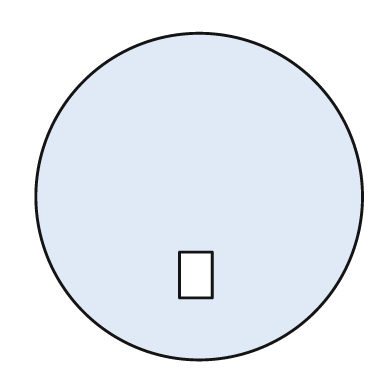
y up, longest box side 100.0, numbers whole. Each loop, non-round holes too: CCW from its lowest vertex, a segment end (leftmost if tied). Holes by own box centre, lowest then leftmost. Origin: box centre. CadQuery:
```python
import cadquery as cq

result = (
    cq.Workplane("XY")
    .moveTo(0.0, 0.0)
    .circle(50.0)
    .moveTo(-6.0, -31.0)
    .lineTo(4.0, -31.0)
    .lineTo(4.0, -17.0)
    .lineTo(-6.0, -17.0)
    .close()
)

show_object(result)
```